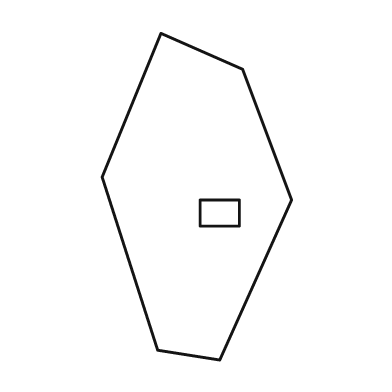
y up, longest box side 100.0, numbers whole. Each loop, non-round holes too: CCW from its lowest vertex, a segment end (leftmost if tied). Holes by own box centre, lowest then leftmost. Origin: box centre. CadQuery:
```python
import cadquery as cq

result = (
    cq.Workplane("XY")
    .moveTo(7.0, -50.0)
    .lineTo(29.0, -1.0)
    .lineTo(14.0, 39.0)
    .lineTo(-11.0, 50.0)
    .lineTo(-29.0, 6.0)
    .lineTo(-12.0, -47.0)
    .close()
    .moveTo(1.0, -9.0)
    .lineTo(13.0, -9.0)
    .lineTo(13.0, -1.0)
    .lineTo(1.0, -1.0)
    .close()
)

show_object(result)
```